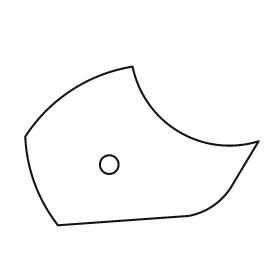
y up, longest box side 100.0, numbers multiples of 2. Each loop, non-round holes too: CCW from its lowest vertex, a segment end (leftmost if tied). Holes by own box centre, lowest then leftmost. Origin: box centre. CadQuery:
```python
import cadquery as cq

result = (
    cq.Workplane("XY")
    .moveTo(-36.0, -34.0)
    .lineTo(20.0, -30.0)
    .threePointArc((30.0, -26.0), (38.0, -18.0))
    .lineTo(50.0, 2.0)
    .threePointArc((16.0, 6.0), (-4.0, 34.0))
    .threePointArc((-30.0, 24.0), (-50.0, 4.0))
    .threePointArc((-46.0, -16.0), (-36.0, -34.0))
    .close()
    .moveTo(-14.0, -8.0)
    .circle(4.0)
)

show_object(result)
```